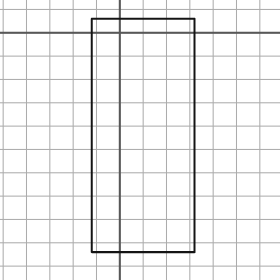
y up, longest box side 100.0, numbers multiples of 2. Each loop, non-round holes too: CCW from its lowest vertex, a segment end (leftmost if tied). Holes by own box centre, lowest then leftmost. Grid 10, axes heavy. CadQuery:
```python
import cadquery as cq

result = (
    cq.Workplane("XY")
    .moveTo(-12.0, -94.0)
    .lineTo(32.0, -94.0)
    .lineTo(32.0, 6.0)
    .lineTo(-12.0, 6.0)
    .close()
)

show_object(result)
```